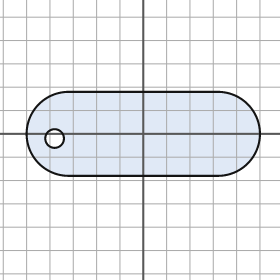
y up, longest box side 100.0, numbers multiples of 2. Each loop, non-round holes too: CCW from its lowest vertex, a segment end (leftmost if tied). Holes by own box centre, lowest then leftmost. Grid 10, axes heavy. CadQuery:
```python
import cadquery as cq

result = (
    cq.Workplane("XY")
    .moveTo(-32.0, -18.0)
    .lineTo(32.0, -18.0)
    .threePointArc((50.0, 0.0), (32.0, 18.0))
    .lineTo(-32.0, 18.0)
    .threePointArc((-50.0, 0.0), (-32.0, -18.0))
    .close()
    .moveTo(-38.0, -2.0)
    .circle(4.0)
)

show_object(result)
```